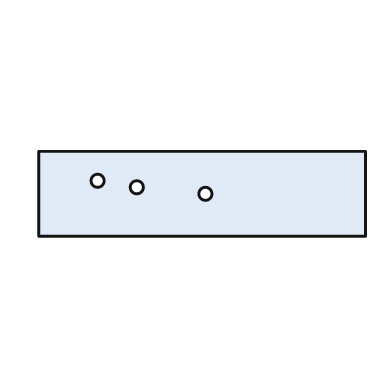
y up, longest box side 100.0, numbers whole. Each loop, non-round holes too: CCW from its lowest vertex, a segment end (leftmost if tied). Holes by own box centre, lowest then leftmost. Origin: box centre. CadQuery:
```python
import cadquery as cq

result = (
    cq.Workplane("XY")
    .moveTo(-50.0, -13.0)
    .lineTo(50.0, -13.0)
    .lineTo(50.0, 13.0)
    .lineTo(-50.0, 13.0)
    .close()
    .moveTo(1.0, 0.0)
    .circle(2.0)
    .moveTo(-20.0, 2.0)
    .circle(2.0)
    .moveTo(-32.0, 4.0)
    .circle(2.0)
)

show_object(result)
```